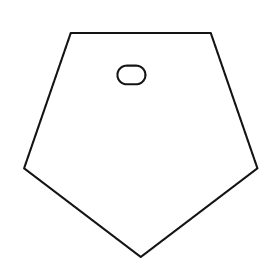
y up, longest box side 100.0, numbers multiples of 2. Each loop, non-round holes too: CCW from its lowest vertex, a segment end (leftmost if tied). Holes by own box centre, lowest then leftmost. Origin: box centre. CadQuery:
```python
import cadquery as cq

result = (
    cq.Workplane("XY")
    .moveTo(0.0, -48.0)
    .lineTo(50.0, -10.0)
    .lineTo(30.0, 48.0)
    .lineTo(-30.0, 48.0)
    .lineTo(-50.0, -10.0)
    .close()
    .moveTo(-6.0, 26.0)
    .lineTo(-2.0, 26.0)
    .threePointArc((2.0, 30.0), (-2.0, 34.0))
    .lineTo(-6.0, 34.0)
    .threePointArc((-10.0, 30.0), (-6.0, 26.0))
    .close()
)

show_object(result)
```